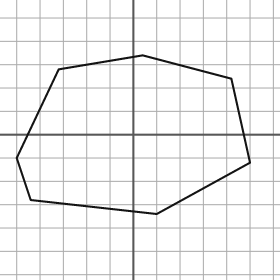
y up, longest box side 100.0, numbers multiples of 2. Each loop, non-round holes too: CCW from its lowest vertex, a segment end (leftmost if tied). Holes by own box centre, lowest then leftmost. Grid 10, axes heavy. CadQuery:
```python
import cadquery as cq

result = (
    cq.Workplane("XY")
    .moveTo(10.0, -34.0)
    .lineTo(50.0, -12.0)
    .lineTo(42.0, 24.0)
    .lineTo(4.0, 34.0)
    .lineTo(-32.0, 28.0)
    .lineTo(-50.0, -10.0)
    .lineTo(-44.0, -28.0)
    .close()
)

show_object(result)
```